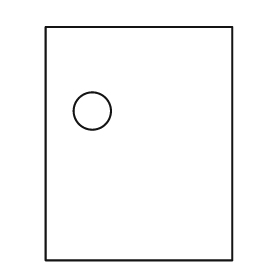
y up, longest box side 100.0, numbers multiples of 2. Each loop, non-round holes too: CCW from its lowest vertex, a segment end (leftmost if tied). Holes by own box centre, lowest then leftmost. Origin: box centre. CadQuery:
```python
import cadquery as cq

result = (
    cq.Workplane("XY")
    .moveTo(-40.0, -50.0)
    .lineTo(40.0, -50.0)
    .lineTo(40.0, 50.0)
    .lineTo(-40.0, 50.0)
    .close()
    .moveTo(-20.0, 14.0)
    .circle(8.0)
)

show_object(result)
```